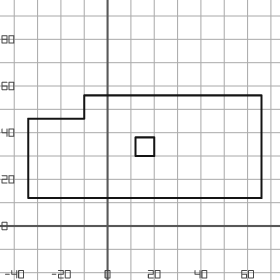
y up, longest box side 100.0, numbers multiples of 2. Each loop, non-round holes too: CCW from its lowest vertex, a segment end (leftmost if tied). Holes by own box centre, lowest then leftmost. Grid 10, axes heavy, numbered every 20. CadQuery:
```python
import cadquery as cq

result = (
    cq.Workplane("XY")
    .moveTo(-34.0, 12.0)
    .lineTo(66.0, 12.0)
    .lineTo(66.0, 56.0)
    .lineTo(-10.0, 56.0)
    .lineTo(-10.0, 46.0)
    .lineTo(-34.0, 46.0)
    .close()
    .moveTo(12.0, 30.0)
    .lineTo(20.0, 30.0)
    .lineTo(20.0, 38.0)
    .lineTo(12.0, 38.0)
    .close()
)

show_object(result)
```